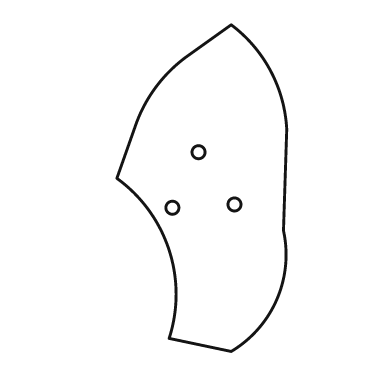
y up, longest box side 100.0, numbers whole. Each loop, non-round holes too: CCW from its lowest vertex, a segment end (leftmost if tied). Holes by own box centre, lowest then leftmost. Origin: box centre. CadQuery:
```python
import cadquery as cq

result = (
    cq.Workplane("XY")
    .moveTo(9.0, -50.0)
    .threePointArc((23.0, -34.0), (25.0, -13.0))
    .lineTo(26.0, 18.0)
    .threePointArc((21.0, 36.0), (9.0, 50.0))
    .lineTo(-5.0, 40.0)
    .threePointArc((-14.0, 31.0), (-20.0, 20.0))
    .lineTo(-26.0, 3.0)
    .threePointArc((-10.0, -19.0), (-10.0, -46.0))
    .close()
    .moveTo(-9.0, -6.0)
    .circle(2.0)
    .moveTo(10.0, -5.0)
    .circle(2.0)
    .moveTo(-1.0, 11.0)
    .circle(2.0)
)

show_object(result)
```